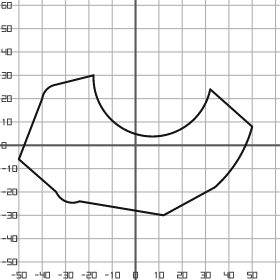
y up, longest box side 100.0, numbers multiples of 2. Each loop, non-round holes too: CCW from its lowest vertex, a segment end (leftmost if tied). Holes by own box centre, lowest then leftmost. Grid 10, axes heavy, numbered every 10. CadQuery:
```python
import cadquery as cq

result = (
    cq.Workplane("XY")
    .moveTo(12.0, -30.0)
    .lineTo(34.0, -18.0)
    .threePointArc((44.0, -6.0), (50.0, 8.0))
    .lineTo(32.0, 24.0)
    .threePointArc((4.0, 4.0), (-18.0, 30.0))
    .lineTo(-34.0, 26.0)
    .threePointArc((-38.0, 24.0), (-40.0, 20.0))
    .lineTo(-50.0, -6.0)
    .lineTo(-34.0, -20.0)
    .threePointArc((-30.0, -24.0), (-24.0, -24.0))
    .close()
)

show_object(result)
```